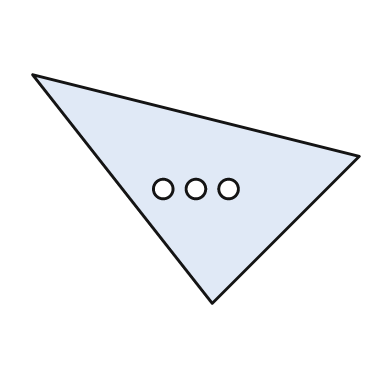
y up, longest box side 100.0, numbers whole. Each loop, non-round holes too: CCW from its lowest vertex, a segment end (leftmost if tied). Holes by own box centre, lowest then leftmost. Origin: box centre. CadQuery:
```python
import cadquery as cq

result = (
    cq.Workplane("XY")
    .moveTo(5.0, -35.0)
    .lineTo(50.0, 10.0)
    .lineTo(-50.0, 35.0)
    .close()
    .moveTo(-10.0, 0.0)
    .circle(3.0)
    .moveTo(0.0, 0.0)
    .circle(3.0)
    .moveTo(10.0, 0.0)
    .circle(3.0)
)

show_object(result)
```